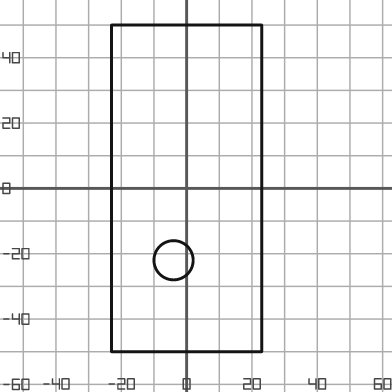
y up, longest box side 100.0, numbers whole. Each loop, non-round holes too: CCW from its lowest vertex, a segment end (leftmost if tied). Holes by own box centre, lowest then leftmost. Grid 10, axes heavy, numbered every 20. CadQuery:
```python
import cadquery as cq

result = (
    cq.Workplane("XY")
    .moveTo(-23.0, -50.0)
    .lineTo(23.0, -50.0)
    .lineTo(23.0, 50.0)
    .lineTo(-23.0, 50.0)
    .close()
    .moveTo(-4.0, -22.0)
    .circle(6.0)
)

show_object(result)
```